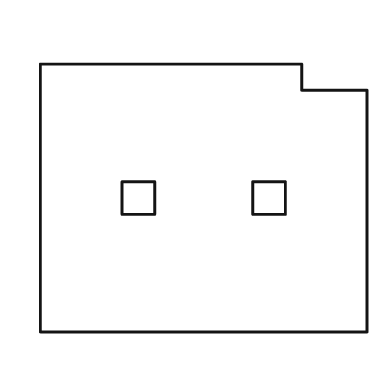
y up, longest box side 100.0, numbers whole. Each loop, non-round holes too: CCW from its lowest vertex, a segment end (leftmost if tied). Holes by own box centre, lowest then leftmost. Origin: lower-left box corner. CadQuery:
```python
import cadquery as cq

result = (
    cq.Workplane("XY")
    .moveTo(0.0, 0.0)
    .lineTo(100.0, 0.0)
    .lineTo(100.0, 74.0)
    .lineTo(80.0, 74.0)
    .lineTo(80.0, 82.0)
    .lineTo(0.0, 82.0)
    .close()
    .moveTo(25.0, 36.0)
    .lineTo(35.0, 36.0)
    .lineTo(35.0, 46.0)
    .lineTo(25.0, 46.0)
    .close()
    .moveTo(65.0, 36.0)
    .lineTo(75.0, 36.0)
    .lineTo(75.0, 46.0)
    .lineTo(65.0, 46.0)
    .close()
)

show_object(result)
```